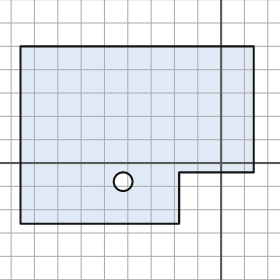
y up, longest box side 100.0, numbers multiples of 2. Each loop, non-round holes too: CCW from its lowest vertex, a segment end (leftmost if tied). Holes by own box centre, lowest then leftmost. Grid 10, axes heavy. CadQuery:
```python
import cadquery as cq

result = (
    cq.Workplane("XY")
    .moveTo(-86.0, -26.0)
    .lineTo(-18.0, -26.0)
    .lineTo(-18.0, -4.0)
    .lineTo(14.0, -4.0)
    .lineTo(14.0, 50.0)
    .lineTo(-86.0, 50.0)
    .close()
    .moveTo(-42.0, -8.0)
    .circle(4.0)
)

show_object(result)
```